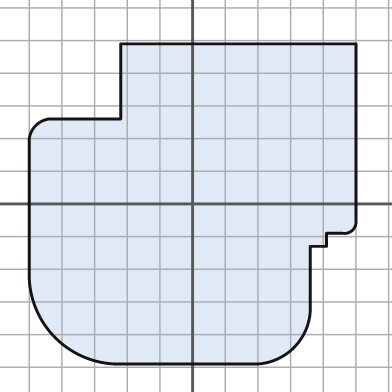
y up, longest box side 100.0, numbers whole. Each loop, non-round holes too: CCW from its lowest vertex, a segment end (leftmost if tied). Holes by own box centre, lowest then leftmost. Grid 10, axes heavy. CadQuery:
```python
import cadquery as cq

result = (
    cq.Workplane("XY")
    .moveTo(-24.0, -49.0)
    .lineTo(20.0, -49.0)
    .threePointArc((31.0, -44.0), (36.0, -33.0))
    .lineTo(36.0, -13.0)
    .lineTo(41.0, -13.0)
    .lineTo(41.0, -9.0)
    .lineTo(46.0, -9.0)
    .threePointArc((49.0, -8.0), (50.0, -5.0))
    .lineTo(50.0, 49.0)
    .lineTo(-22.0, 49.0)
    .lineTo(-22.0, 26.0)
    .lineTo(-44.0, 26.0)
    .threePointArc((-48.0, 24.0), (-50.0, 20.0))
    .lineTo(-50.0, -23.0)
    .threePointArc((-42.0, -41.0), (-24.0, -49.0))
    .close()
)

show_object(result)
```